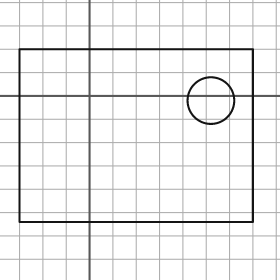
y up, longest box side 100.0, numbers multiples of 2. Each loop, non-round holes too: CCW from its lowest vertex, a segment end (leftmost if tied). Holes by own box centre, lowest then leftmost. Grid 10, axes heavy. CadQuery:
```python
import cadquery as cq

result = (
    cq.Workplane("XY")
    .moveTo(-30.0, -54.0)
    .lineTo(70.0, -54.0)
    .lineTo(70.0, 20.0)
    .lineTo(-30.0, 20.0)
    .close()
    .moveTo(52.0, -2.0)
    .circle(10.0)
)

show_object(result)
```